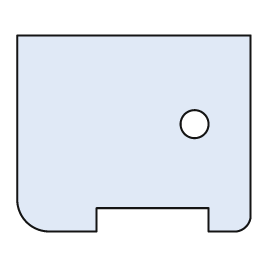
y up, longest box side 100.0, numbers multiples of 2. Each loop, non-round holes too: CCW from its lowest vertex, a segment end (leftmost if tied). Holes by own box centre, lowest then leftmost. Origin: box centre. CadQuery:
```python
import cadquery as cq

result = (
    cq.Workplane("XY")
    .moveTo(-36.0, -42.0)
    .lineTo(-16.0, -42.0)
    .lineTo(-16.0, -32.0)
    .lineTo(32.0, -32.0)
    .lineTo(32.0, -42.0)
    .lineTo(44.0, -42.0)
    .threePointArc((48.0, -40.0), (50.0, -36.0))
    .lineTo(50.0, 42.0)
    .lineTo(-50.0, 42.0)
    .lineTo(-50.0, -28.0)
    .threePointArc((-46.0, -38.0), (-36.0, -42.0))
    .close()
    .moveTo(26.0, 4.0)
    .circle(6.0)
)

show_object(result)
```